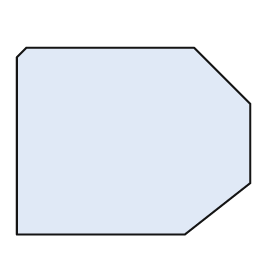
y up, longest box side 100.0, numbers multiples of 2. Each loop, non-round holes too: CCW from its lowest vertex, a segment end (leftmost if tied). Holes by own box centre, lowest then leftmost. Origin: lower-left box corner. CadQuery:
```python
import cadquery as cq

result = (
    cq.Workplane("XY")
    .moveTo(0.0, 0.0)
    .lineTo(72.0, 0.0)
    .lineTo(100.0, 22.0)
    .lineTo(100.0, 56.0)
    .lineTo(76.0, 80.0)
    .lineTo(4.0, 80.0)
    .lineTo(0.0, 76.0)
    .close()
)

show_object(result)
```